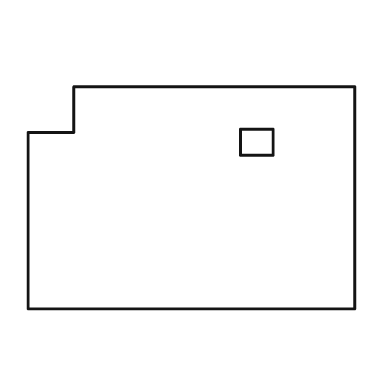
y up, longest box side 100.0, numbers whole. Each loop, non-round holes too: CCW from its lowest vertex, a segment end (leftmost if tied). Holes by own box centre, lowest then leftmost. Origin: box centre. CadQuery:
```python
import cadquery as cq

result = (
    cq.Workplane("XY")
    .moveTo(-50.0, -34.0)
    .lineTo(50.0, -34.0)
    .lineTo(50.0, 34.0)
    .lineTo(-36.0, 34.0)
    .lineTo(-36.0, 20.0)
    .lineTo(-50.0, 20.0)
    .close()
    .moveTo(15.0, 13.0)
    .lineTo(25.0, 13.0)
    .lineTo(25.0, 21.0)
    .lineTo(15.0, 21.0)
    .close()
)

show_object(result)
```